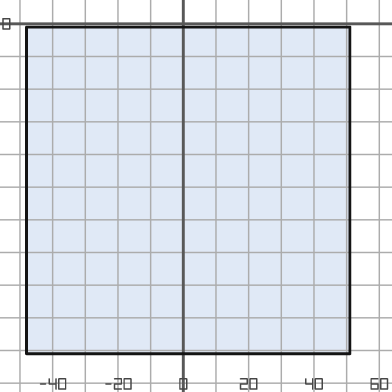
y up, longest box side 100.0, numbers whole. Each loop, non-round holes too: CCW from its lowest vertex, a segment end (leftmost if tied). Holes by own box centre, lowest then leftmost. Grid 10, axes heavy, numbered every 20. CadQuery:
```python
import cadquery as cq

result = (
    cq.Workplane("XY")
    .moveTo(-48.0, -101.0)
    .lineTo(51.0, -101.0)
    .lineTo(51.0, -1.0)
    .lineTo(-48.0, -1.0)
    .close()
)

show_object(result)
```